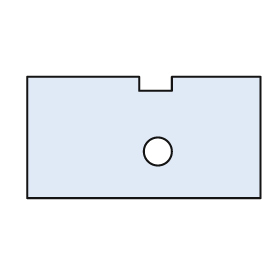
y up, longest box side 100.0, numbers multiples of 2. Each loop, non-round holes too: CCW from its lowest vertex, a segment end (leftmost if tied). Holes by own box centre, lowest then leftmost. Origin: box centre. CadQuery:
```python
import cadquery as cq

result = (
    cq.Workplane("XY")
    .moveTo(-50.0, -26.0)
    .lineTo(50.0, -26.0)
    .lineTo(50.0, 26.0)
    .lineTo(12.0, 26.0)
    .lineTo(12.0, 20.0)
    .lineTo(-2.0, 20.0)
    .lineTo(-2.0, 26.0)
    .lineTo(-50.0, 26.0)
    .close()
    .moveTo(6.0, -6.0)
    .circle(6.0)
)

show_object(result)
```